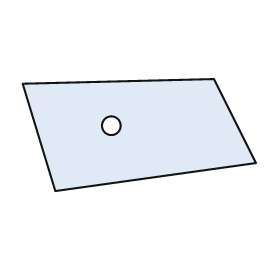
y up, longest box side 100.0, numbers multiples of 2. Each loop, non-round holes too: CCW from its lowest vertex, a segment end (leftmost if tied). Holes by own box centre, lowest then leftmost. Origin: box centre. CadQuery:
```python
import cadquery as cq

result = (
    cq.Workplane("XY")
    .moveTo(-36.0, -24.0)
    .lineTo(50.0, -12.0)
    .lineTo(32.0, 24.0)
    .lineTo(-50.0, 22.0)
    .close()
    .moveTo(-12.0, 4.0)
    .circle(4.0)
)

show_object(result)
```